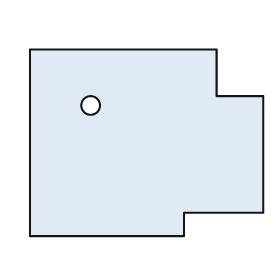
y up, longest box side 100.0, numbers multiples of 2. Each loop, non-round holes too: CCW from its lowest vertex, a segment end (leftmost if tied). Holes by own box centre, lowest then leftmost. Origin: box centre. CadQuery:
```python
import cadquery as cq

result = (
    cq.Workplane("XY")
    .moveTo(-50.0, -40.0)
    .lineTo(16.0, -40.0)
    .lineTo(16.0, -30.0)
    .lineTo(50.0, -30.0)
    .lineTo(50.0, 20.0)
    .lineTo(30.0, 20.0)
    .lineTo(30.0, 40.0)
    .lineTo(-50.0, 40.0)
    .close()
    .moveTo(-24.0, 16.0)
    .circle(4.0)
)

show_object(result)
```